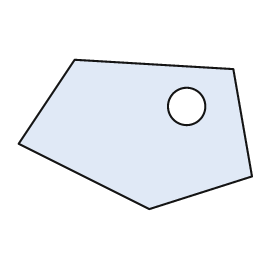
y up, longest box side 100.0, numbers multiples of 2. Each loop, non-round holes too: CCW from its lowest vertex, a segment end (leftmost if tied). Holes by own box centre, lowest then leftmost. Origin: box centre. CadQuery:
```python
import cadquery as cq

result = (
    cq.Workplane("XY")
    .moveTo(6.0, -32.0)
    .lineTo(50.0, -18.0)
    .lineTo(42.0, 28.0)
    .lineTo(-26.0, 32.0)
    .lineTo(-50.0, -4.0)
    .close()
    .moveTo(22.0, 12.0)
    .circle(8.0)
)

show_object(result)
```